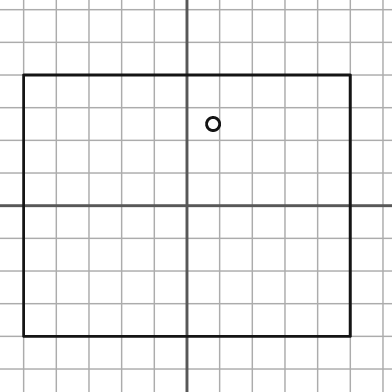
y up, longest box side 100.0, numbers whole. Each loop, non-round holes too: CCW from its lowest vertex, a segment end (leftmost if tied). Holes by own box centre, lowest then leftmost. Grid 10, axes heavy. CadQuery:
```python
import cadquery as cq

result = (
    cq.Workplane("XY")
    .moveTo(-50.0, -40.0)
    .lineTo(50.0, -40.0)
    .lineTo(50.0, 40.0)
    .lineTo(-50.0, 40.0)
    .close()
    .moveTo(8.0, 25.0)
    .circle(2.0)
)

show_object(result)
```